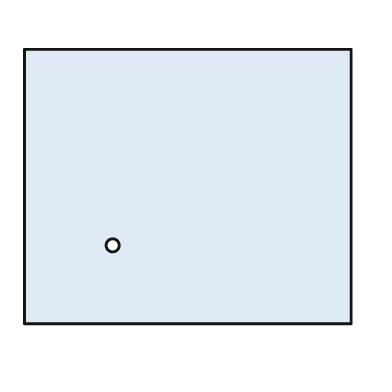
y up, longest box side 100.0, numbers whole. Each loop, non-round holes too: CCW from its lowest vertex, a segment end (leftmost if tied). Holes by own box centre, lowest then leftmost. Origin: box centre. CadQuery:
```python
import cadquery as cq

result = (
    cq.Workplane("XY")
    .moveTo(-50.0, -42.0)
    .lineTo(50.0, -42.0)
    .lineTo(50.0, 42.0)
    .lineTo(-50.0, 42.0)
    .close()
    .moveTo(-23.0, -18.0)
    .circle(2.0)
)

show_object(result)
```